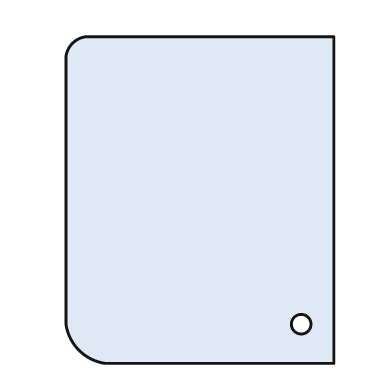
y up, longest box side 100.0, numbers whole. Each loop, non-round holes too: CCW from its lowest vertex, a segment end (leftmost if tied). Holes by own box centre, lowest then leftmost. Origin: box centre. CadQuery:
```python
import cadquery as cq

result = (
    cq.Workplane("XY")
    .moveTo(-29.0, -50.0)
    .lineTo(41.0, -50.0)
    .lineTo(41.0, 50.0)
    .lineTo(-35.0, 50.0)
    .threePointArc((-39.0, 48.0), (-41.0, 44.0))
    .lineTo(-41.0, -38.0)
    .threePointArc((-37.0, -46.0), (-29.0, -50.0))
    .close()
    .moveTo(31.0, -38.0)
    .circle(3.0)
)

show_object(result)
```